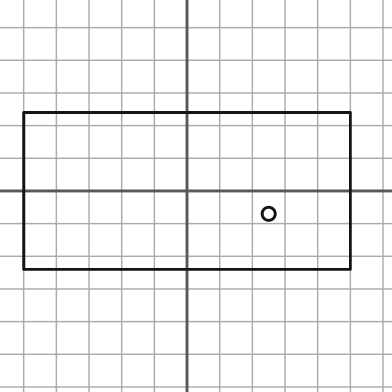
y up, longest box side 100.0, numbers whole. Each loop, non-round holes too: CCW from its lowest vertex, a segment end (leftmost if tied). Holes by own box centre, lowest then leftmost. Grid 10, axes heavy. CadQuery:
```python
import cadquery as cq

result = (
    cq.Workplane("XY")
    .moveTo(-50.0, -24.0)
    .lineTo(50.0, -24.0)
    .lineTo(50.0, 24.0)
    .lineTo(-50.0, 24.0)
    .close()
    .moveTo(25.0, -7.0)
    .circle(2.0)
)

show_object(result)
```